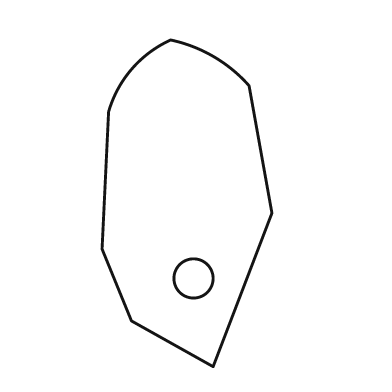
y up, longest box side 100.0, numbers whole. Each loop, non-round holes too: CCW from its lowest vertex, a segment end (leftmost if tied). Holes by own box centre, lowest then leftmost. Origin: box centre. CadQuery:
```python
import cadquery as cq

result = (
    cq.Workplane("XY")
    .moveTo(8.0, -50.0)
    .lineTo(26.0, -3.0)
    .lineTo(19.0, 36.0)
    .threePointArc((8.0, 45.0), (-5.0, 50.0))
    .threePointArc((-17.0, 41.0), (-24.0, 28.0))
    .lineTo(-26.0, -14.0)
    .lineTo(-17.0, -36.0)
    .close()
    .moveTo(2.0, -23.0)
    .circle(6.0)
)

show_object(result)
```